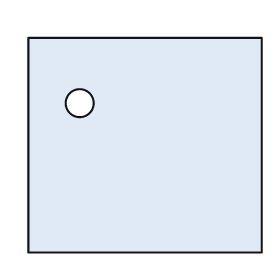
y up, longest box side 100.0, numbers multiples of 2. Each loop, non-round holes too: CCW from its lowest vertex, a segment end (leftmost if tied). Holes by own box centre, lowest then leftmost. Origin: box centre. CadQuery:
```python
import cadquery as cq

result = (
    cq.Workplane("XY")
    .moveTo(-50.0, -46.0)
    .lineTo(50.0, -46.0)
    .lineTo(50.0, 46.0)
    .lineTo(-50.0, 46.0)
    .close()
    .moveTo(-28.0, 18.0)
    .circle(6.0)
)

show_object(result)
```